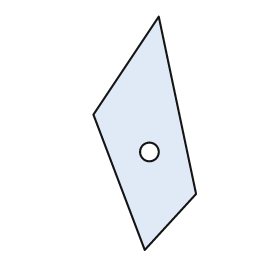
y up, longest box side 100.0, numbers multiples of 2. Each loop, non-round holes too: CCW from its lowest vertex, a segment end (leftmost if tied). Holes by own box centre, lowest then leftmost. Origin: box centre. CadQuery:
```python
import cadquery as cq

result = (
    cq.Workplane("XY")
    .moveTo(0.0, -50.0)
    .lineTo(22.0, -26.0)
    .lineTo(6.0, 50.0)
    .lineTo(-22.0, 8.0)
    .close()
    .moveTo(2.0, -8.0)
    .circle(4.0)
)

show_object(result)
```